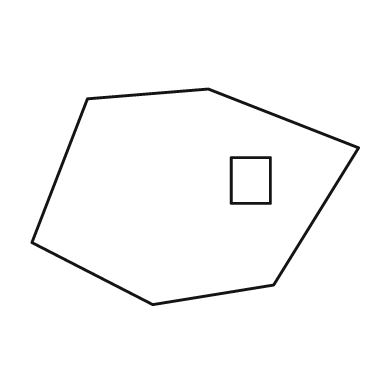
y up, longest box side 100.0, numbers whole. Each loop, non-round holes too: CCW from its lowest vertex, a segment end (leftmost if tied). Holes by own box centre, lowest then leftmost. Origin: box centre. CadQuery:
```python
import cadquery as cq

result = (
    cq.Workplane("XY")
    .moveTo(-13.0, -33.0)
    .lineTo(24.0, -27.0)
    .lineTo(50.0, 15.0)
    .lineTo(4.0, 33.0)
    .lineTo(-33.0, 30.0)
    .lineTo(-50.0, -14.0)
    .close()
    .moveTo(11.0, -2.0)
    .lineTo(23.0, -2.0)
    .lineTo(23.0, 12.0)
    .lineTo(11.0, 12.0)
    .close()
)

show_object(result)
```